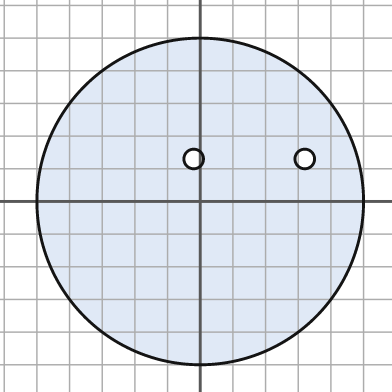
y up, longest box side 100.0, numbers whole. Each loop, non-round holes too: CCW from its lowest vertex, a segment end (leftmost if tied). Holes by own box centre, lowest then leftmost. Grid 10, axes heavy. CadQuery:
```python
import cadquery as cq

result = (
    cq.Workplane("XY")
    .moveTo(0.0, 0.0)
    .circle(50.0)
    .moveTo(-2.0, 13.0)
    .circle(3.0)
    .moveTo(32.0, 13.0)
    .circle(3.0)
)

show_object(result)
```